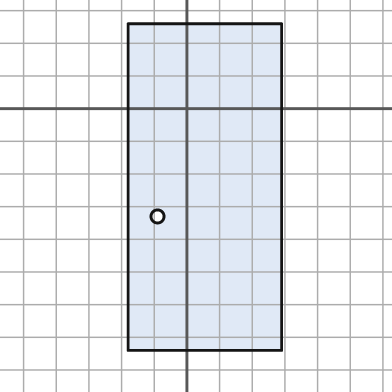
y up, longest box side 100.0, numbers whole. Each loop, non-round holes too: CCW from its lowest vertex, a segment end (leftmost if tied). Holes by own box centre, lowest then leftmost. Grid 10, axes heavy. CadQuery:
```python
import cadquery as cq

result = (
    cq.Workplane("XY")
    .moveTo(-18.0, -74.0)
    .lineTo(29.0, -74.0)
    .lineTo(29.0, 26.0)
    .lineTo(-18.0, 26.0)
    .close()
    .moveTo(-9.0, -33.0)
    .circle(2.0)
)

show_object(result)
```